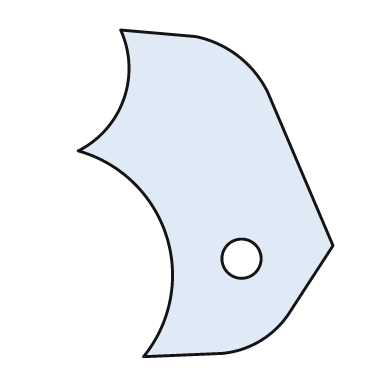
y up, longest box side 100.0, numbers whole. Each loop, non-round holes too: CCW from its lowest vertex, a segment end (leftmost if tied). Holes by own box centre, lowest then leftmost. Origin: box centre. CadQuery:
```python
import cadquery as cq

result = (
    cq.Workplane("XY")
    .moveTo(-19.0, -50.0)
    .lineTo(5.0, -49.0)
    .threePointArc((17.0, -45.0), (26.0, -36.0))
    .lineTo(39.0, -16.0)
    .lineTo(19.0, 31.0)
    .threePointArc((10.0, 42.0), (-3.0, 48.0))
    .lineTo(-26.0, 50.0)
    .threePointArc((-25.0, 29.0), (-39.0, 13.0))
    .threePointArc((-12.0, -13.0), (-19.0, -50.0))
    .close()
    .moveTo(11.0, -20.0)
    .circle(6.0)
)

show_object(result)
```